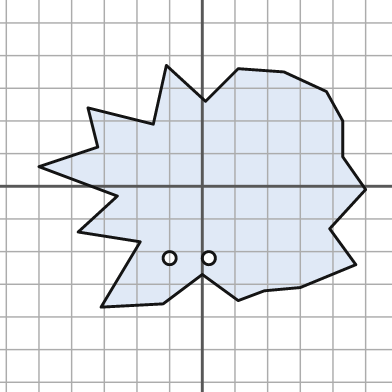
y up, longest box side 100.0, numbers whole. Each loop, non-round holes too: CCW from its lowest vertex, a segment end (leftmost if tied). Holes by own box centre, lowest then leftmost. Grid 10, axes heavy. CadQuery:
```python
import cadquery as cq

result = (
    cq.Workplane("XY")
    .moveTo(-31.0, -37.0)
    .lineTo(-12.0, -36.0)
    .lineTo(0.0, -27.0)
    .lineTo(11.0, -35.0)
    .lineTo(19.0, -32.0)
    .lineTo(30.0, -31.0)
    .lineTo(47.0, -24.0)
    .lineTo(39.0, -13.0)
    .lineTo(50.0, -1.0)
    .lineTo(43.0, 9.0)
    .lineTo(43.0, 20.0)
    .lineTo(38.0, 29.0)
    .lineTo(25.0, 35.0)
    .lineTo(11.0, 36.0)
    .lineTo(1.0, 26.0)
    .lineTo(-11.0, 37.0)
    .lineTo(-15.0, 19.0)
    .lineTo(-35.0, 24.0)
    .lineTo(-32.0, 12.0)
    .lineTo(-50.0, 6.0)
    .lineTo(-26.0, -3.0)
    .lineTo(-38.0, -14.0)
    .lineTo(-19.0, -17.0)
    .close()
    .moveTo(-10.0, -22.0)
    .circle(2.0)
    .moveTo(2.0, -22.0)
    .circle(2.0)
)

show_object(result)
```